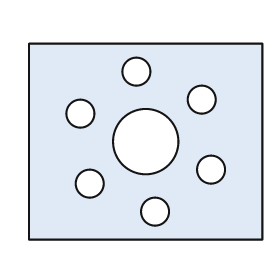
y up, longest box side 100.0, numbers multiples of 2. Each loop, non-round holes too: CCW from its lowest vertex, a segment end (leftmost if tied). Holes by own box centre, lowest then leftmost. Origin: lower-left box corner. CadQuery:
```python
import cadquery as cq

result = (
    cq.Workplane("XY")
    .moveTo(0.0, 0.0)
    .lineTo(100.0, 0.0)
    .lineTo(100.0, 84.0)
    .lineTo(0.0, 84.0)
    .close()
    .moveTo(54.0, 12.0)
    .circle(6.0)
    .moveTo(26.0, 24.0)
    .circle(6.0)
    .moveTo(78.0, 30.0)
    .circle(6.0)
    .moveTo(50.0, 42.0)
    .circle(14.0)
    .moveTo(22.0, 54.0)
    .circle(6.0)
    .moveTo(74.0, 60.0)
    .circle(6.0)
    .moveTo(46.0, 72.0)
    .circle(6.0)
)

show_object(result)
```